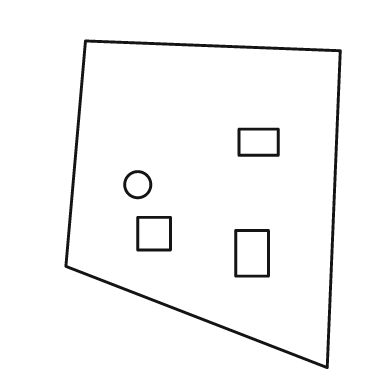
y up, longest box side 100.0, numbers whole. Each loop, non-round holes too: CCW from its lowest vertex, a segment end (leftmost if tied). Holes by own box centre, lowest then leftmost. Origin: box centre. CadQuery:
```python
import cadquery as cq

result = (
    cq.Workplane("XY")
    .moveTo(38.0, -50.0)
    .lineTo(42.0, 47.0)
    .lineTo(-36.0, 50.0)
    .lineTo(-42.0, -19.0)
    .close()
    .moveTo(10.0, -22.0)
    .lineTo(20.0, -22.0)
    .lineTo(20.0, -8.0)
    .lineTo(10.0, -8.0)
    .close()
    .moveTo(-20.0, -14.0)
    .lineTo(-10.0, -14.0)
    .lineTo(-10.0, -4.0)
    .lineTo(-20.0, -4.0)
    .close()
    .moveTo(-20.0, 6.0)
    .circle(4.0)
    .moveTo(11.0, 15.0)
    .lineTo(23.0, 15.0)
    .lineTo(23.0, 23.0)
    .lineTo(11.0, 23.0)
    .close()
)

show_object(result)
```